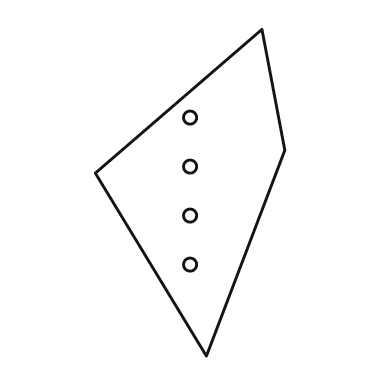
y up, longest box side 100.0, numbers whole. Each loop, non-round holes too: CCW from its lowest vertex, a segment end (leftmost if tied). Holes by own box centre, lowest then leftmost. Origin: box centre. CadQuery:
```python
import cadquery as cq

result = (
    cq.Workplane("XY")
    .moveTo(5.0, -50.0)
    .lineTo(29.0, 13.0)
    .lineTo(22.0, 50.0)
    .lineTo(-29.0, 6.0)
    .close()
    .moveTo(0.0, -22.0)
    .circle(2.0)
    .moveTo(0.0, -7.0)
    .circle(2.0)
    .moveTo(0.0, 8.0)
    .circle(2.0)
    .moveTo(0.0, 23.0)
    .circle(2.0)
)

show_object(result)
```